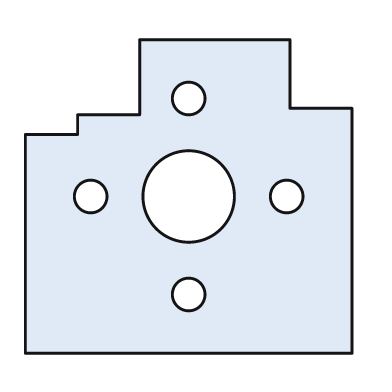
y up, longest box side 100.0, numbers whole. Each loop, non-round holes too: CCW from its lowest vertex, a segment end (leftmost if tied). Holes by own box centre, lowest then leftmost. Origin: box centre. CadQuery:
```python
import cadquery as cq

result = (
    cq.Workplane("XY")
    .moveTo(-50.0, -48.0)
    .lineTo(50.0, -48.0)
    .lineTo(50.0, 27.0)
    .lineTo(31.0, 27.0)
    .lineTo(31.0, 48.0)
    .lineTo(-15.0, 48.0)
    .lineTo(-15.0, 25.0)
    .lineTo(-34.0, 25.0)
    .lineTo(-34.0, 19.0)
    .lineTo(-50.0, 19.0)
    .close()
    .moveTo(0.0, -30.0)
    .circle(5.0)
    .moveTo(-30.0, 0.0)
    .circle(5.0)
    .moveTo(0.0, 0.0)
    .circle(14.0)
    .moveTo(30.0, 0.0)
    .circle(5.0)
    .moveTo(0.0, 30.0)
    .circle(5.0)
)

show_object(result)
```